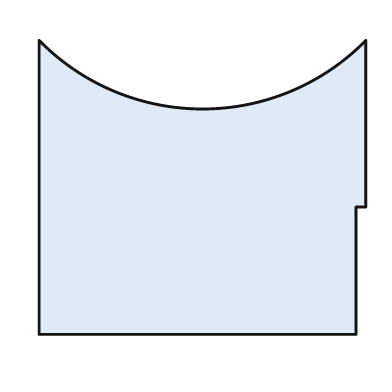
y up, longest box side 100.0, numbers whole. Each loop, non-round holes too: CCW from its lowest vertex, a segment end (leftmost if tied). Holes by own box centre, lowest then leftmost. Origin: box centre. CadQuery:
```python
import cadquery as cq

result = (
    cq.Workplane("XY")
    .moveTo(-50.0, -45.0)
    .lineTo(47.0, -45.0)
    .lineTo(47.0, -6.0)
    .lineTo(50.0, -6.0)
    .lineTo(50.0, 45.0)
    .threePointArc((0.0, 24.0), (-50.0, 45.0))
    .close()
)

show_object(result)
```